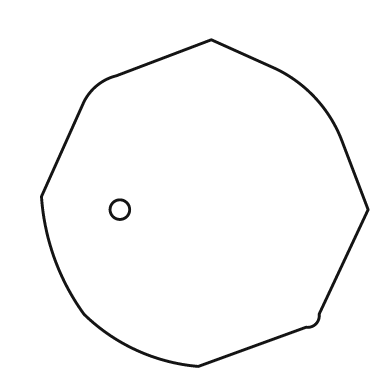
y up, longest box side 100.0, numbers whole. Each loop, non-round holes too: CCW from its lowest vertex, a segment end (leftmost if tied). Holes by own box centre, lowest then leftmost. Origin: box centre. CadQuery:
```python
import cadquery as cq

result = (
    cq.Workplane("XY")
    .moveTo(-2.0, -50.0)
    .lineTo(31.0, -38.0)
    .threePointArc((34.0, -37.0), (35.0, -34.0))
    .lineTo(50.0, -2.0)
    .lineTo(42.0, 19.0)
    .threePointArc((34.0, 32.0), (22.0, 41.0))
    .lineTo(2.0, 50.0)
    .lineTo(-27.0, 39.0)
    .threePointArc((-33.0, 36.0), (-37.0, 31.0))
    .lineTo(-50.0, 2.0)
    .threePointArc((-46.0, -17.0), (-37.0, -34.0))
    .threePointArc((-21.0, -45.0), (-2.0, -50.0))
    .close()
    .moveTo(-26.0, -2.0)
    .circle(3.0)
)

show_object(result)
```